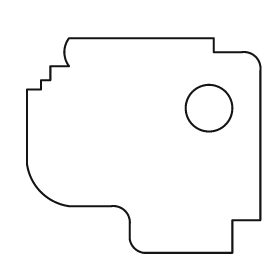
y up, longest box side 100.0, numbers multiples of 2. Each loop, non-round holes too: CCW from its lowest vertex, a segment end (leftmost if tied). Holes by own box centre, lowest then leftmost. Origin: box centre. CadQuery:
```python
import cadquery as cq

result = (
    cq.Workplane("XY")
    .moveTo(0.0, -46.0)
    .lineTo(38.0, -46.0)
    .lineTo(38.0, -32.0)
    .lineTo(50.0, -32.0)
    .lineTo(50.0, 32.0)
    .threePointArc((48.0, 38.0), (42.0, 40.0))
    .lineTo(30.0, 40.0)
    .lineTo(30.0, 46.0)
    .lineTo(-32.0, 46.0)
    .threePointArc((-34.0, 40.0), (-32.0, 34.0))
    .lineTo(-40.0, 34.0)
    .lineTo(-40.0, 28.0)
    .lineTo(-44.0, 28.0)
    .lineTo(-44.0, 24.0)
    .lineTo(-50.0, 24.0)
    .lineTo(-50.0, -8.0)
    .threePointArc((-44.0, -20.0), (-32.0, -26.0))
    .lineTo(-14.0, -26.0)
    .threePointArc((-8.0, -28.0), (-6.0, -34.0))
    .lineTo(-6.0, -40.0)
    .threePointArc((-4.0, -44.0), (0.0, -46.0))
    .close()
    .moveTo(28.0, 16.0)
    .circle(10.0)
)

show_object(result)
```